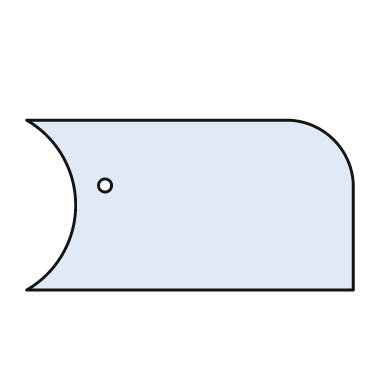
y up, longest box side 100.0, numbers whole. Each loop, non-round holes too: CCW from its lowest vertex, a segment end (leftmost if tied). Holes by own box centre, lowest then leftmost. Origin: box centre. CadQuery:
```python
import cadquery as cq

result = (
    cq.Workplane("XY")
    .moveTo(-50.0, -26.0)
    .lineTo(50.0, -26.0)
    .lineTo(50.0, 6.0)
    .threePointArc((44.0, 20.0), (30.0, 26.0))
    .lineTo(-50.0, 26.0)
    .threePointArc((-35.0, 0.0), (-50.0, -26.0))
    .close()
    .moveTo(-26.0, 6.0)
    .circle(2.0)
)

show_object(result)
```